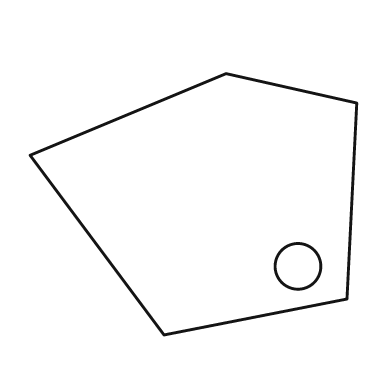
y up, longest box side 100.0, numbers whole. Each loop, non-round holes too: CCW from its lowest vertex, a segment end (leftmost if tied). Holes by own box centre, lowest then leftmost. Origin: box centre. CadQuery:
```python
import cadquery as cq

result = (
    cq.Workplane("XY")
    .moveTo(-9.0, -40.0)
    .lineTo(47.0, -29.0)
    .lineTo(50.0, 31.0)
    .lineTo(10.0, 40.0)
    .lineTo(-50.0, 15.0)
    .close()
    .moveTo(32.0, -19.0)
    .circle(7.0)
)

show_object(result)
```